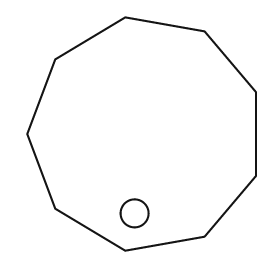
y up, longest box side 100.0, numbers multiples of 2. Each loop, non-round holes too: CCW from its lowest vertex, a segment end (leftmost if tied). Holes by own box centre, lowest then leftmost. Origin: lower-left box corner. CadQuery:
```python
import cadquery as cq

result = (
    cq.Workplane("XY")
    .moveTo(42.0, 0.0)
    .lineTo(76.0, 6.0)
    .lineTo(98.0, 32.0)
    .lineTo(98.0, 68.0)
    .lineTo(76.0, 94.0)
    .lineTo(42.0, 100.0)
    .lineTo(12.0, 82.0)
    .lineTo(0.0, 50.0)
    .lineTo(12.0, 18.0)
    .close()
    .moveTo(46.0, 16.0)
    .circle(6.0)
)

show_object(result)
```